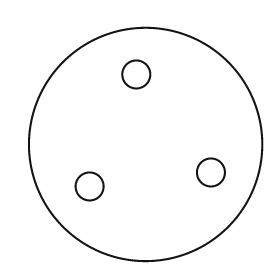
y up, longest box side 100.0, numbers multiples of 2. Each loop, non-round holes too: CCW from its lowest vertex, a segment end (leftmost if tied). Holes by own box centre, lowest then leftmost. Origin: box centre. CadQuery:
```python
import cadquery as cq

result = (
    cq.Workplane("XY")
    .moveTo(0.0, 0.0)
    .circle(50.0)
    .moveTo(-24.0, -18.0)
    .circle(6.0)
    .moveTo(28.0, -12.0)
    .circle(6.0)
    .moveTo(-4.0, 30.0)
    .circle(6.0)
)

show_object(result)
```